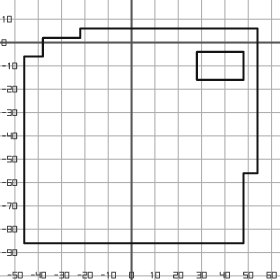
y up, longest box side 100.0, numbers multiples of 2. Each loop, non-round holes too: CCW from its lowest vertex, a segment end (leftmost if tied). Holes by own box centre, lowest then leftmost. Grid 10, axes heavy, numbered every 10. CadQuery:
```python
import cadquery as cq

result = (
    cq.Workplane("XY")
    .moveTo(-46.0, -86.0)
    .lineTo(48.0, -86.0)
    .lineTo(48.0, -56.0)
    .lineTo(54.0, -56.0)
    .lineTo(54.0, 6.0)
    .lineTo(-22.0, 6.0)
    .lineTo(-22.0, 2.0)
    .lineTo(-38.0, 2.0)
    .lineTo(-38.0, -6.0)
    .lineTo(-46.0, -6.0)
    .close()
    .moveTo(28.0, -16.0)
    .lineTo(48.0, -16.0)
    .lineTo(48.0, -4.0)
    .lineTo(28.0, -4.0)
    .close()
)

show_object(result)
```